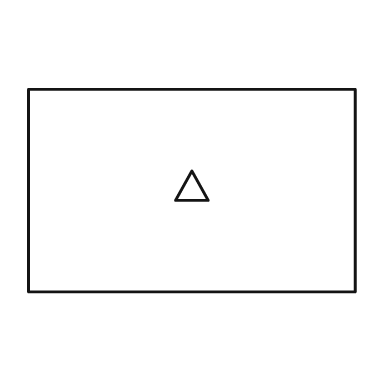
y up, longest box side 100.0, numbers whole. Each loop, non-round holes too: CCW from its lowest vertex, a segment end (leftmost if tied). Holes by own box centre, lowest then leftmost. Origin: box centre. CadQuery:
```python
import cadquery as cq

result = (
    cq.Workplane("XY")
    .moveTo(-50.0, -31.0)
    .lineTo(50.0, -31.0)
    .lineTo(50.0, 31.0)
    .lineTo(-50.0, 31.0)
    .close()
    .moveTo(-5.0, -3.0)
    .lineTo(5.0, -3.0)
    .lineTo(0.0, 6.0)
    .close()
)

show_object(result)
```